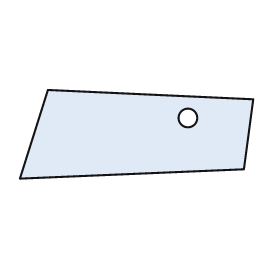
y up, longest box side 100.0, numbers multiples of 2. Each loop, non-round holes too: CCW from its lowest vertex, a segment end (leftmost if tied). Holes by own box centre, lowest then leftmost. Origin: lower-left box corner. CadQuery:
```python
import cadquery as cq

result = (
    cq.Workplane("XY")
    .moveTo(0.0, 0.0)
    .lineTo(96.0, 4.0)
    .lineTo(100.0, 34.0)
    .lineTo(12.0, 38.0)
    .close()
    .moveTo(72.0, 26.0)
    .circle(4.0)
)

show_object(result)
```